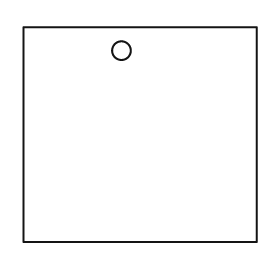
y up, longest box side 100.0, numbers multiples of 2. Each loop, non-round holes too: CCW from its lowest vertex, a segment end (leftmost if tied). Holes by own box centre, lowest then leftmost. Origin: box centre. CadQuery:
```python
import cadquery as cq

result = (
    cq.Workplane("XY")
    .moveTo(-50.0, -46.0)
    .lineTo(50.0, -46.0)
    .lineTo(50.0, 46.0)
    .lineTo(-50.0, 46.0)
    .close()
    .moveTo(-8.0, 36.0)
    .circle(4.0)
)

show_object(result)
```